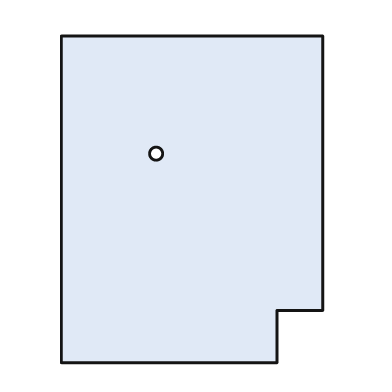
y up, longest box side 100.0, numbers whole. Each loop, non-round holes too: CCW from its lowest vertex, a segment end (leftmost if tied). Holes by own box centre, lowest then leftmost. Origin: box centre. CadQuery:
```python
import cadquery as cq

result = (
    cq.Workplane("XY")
    .moveTo(-40.0, -50.0)
    .lineTo(26.0, -50.0)
    .lineTo(26.0, -34.0)
    .lineTo(40.0, -34.0)
    .lineTo(40.0, 50.0)
    .lineTo(-40.0, 50.0)
    .close()
    .moveTo(-11.0, 14.0)
    .circle(2.0)
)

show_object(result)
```